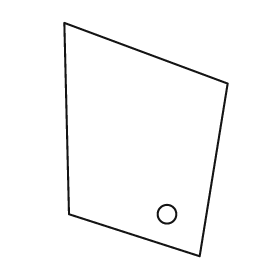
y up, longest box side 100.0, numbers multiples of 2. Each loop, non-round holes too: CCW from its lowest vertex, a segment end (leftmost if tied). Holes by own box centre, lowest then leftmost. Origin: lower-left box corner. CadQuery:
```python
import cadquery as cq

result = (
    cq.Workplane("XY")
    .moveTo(58.0, 0.0)
    .lineTo(70.0, 74.0)
    .lineTo(0.0, 100.0)
    .lineTo(2.0, 18.0)
    .close()
    .moveTo(44.0, 18.0)
    .circle(4.0)
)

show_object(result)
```